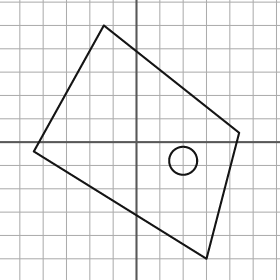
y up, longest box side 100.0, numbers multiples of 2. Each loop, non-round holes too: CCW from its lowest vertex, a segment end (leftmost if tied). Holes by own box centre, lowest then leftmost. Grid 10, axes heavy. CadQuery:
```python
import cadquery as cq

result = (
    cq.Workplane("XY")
    .moveTo(30.0, -50.0)
    .lineTo(44.0, 4.0)
    .lineTo(-14.0, 50.0)
    .lineTo(-44.0, -4.0)
    .close()
    .moveTo(20.0, -8.0)
    .circle(6.0)
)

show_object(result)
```